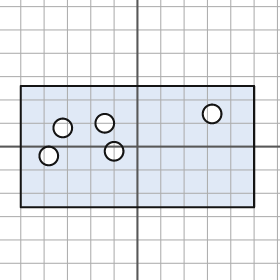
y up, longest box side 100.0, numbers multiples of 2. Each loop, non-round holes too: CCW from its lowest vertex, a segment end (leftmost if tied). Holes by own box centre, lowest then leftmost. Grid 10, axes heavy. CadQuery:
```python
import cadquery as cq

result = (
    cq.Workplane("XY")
    .moveTo(-50.0, -26.0)
    .lineTo(50.0, -26.0)
    .lineTo(50.0, 26.0)
    .lineTo(-50.0, 26.0)
    .close()
    .moveTo(-38.0, -4.0)
    .circle(4.0)
    .moveTo(-10.0, -2.0)
    .circle(4.0)
    .moveTo(-32.0, 8.0)
    .circle(4.0)
    .moveTo(-14.0, 10.0)
    .circle(4.0)
    .moveTo(32.0, 14.0)
    .circle(4.0)
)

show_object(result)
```